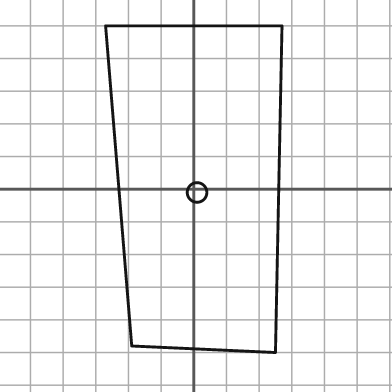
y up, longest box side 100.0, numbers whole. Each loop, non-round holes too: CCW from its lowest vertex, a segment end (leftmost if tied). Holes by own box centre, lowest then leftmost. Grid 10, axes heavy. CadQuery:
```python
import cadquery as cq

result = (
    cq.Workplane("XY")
    .moveTo(25.0, -50.0)
    .lineTo(27.0, 50.0)
    .lineTo(-27.0, 50.0)
    .lineTo(-19.0, -48.0)
    .close()
    .moveTo(1.0, -1.0)
    .circle(3.0)
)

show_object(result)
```